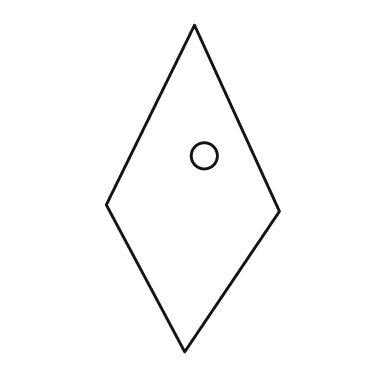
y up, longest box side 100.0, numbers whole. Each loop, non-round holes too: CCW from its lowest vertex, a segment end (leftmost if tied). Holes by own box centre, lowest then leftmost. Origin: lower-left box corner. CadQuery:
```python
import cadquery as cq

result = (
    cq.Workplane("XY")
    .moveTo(24.0, 0.0)
    .lineTo(53.0, 43.0)
    .lineTo(27.0, 100.0)
    .lineTo(0.0, 45.0)
    .close()
    .moveTo(30.0, 60.0)
    .circle(4.0)
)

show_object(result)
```